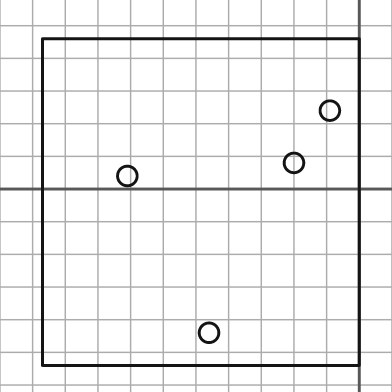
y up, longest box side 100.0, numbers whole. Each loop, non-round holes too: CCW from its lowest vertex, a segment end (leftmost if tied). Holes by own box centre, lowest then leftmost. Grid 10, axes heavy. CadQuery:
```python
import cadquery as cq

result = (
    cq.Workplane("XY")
    .moveTo(-97.0, -54.0)
    .lineTo(0.0, -54.0)
    .lineTo(0.0, 46.0)
    .lineTo(-97.0, 46.0)
    .close()
    .moveTo(-46.0, -44.0)
    .circle(3.0)
    .moveTo(-71.0, 4.0)
    .circle(3.0)
    .moveTo(-20.0, 8.0)
    .circle(3.0)
    .moveTo(-9.0, 24.0)
    .circle(3.0)
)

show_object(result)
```